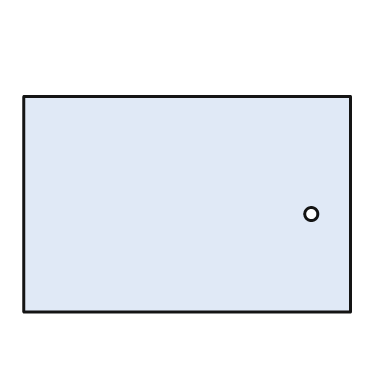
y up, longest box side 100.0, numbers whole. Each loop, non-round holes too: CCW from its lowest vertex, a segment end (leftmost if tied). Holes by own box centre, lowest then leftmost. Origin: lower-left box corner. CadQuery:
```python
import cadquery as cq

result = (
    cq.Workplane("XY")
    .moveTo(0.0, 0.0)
    .lineTo(100.0, 0.0)
    .lineTo(100.0, 66.0)
    .lineTo(0.0, 66.0)
    .close()
    .moveTo(88.0, 30.0)
    .circle(2.0)
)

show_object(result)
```